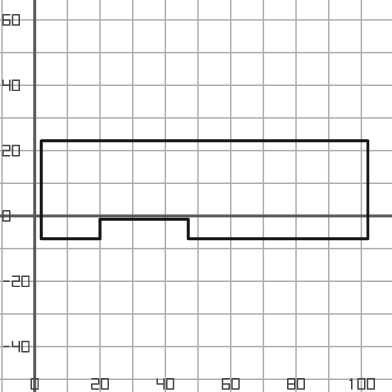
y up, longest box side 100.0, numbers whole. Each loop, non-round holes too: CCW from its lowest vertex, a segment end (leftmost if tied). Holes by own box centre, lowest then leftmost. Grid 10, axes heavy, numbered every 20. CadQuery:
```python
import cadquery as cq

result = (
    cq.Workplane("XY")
    .moveTo(2.0, -7.0)
    .lineTo(20.0, -7.0)
    .lineTo(20.0, -1.0)
    .lineTo(47.0, -1.0)
    .lineTo(47.0, -7.0)
    .lineTo(102.0, -7.0)
    .lineTo(102.0, 23.0)
    .lineTo(2.0, 23.0)
    .close()
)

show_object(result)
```